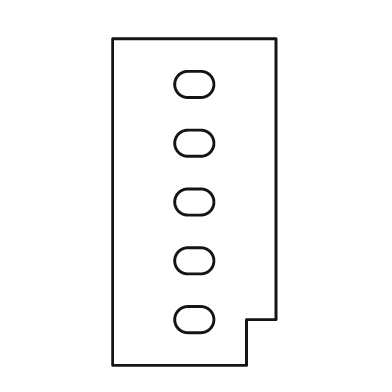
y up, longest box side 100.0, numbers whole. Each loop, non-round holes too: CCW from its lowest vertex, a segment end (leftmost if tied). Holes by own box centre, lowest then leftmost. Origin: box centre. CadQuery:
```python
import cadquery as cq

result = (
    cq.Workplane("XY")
    .moveTo(-25.0, -50.0)
    .lineTo(16.0, -50.0)
    .lineTo(16.0, -36.0)
    .lineTo(25.0, -36.0)
    .lineTo(25.0, 50.0)
    .lineTo(-25.0, 50.0)
    .close()
    .moveTo(-2.0, -40.0)
    .lineTo(2.0, -40.0)
    .threePointArc((6.0, -36.0), (2.0, -32.0))
    .lineTo(-2.0, -32.0)
    .threePointArc((-6.0, -36.0), (-2.0, -40.0))
    .close()
    .moveTo(-2.0, -22.0)
    .lineTo(2.0, -22.0)
    .threePointArc((6.0, -18.0), (2.0, -14.0))
    .lineTo(-2.0, -14.0)
    .threePointArc((-6.0, -18.0), (-2.0, -22.0))
    .close()
    .moveTo(-2.0, -4.0)
    .lineTo(2.0, -4.0)
    .threePointArc((6.0, 0.0), (2.0, 4.0))
    .lineTo(-2.0, 4.0)
    .threePointArc((-6.0, 0.0), (-2.0, -4.0))
    .close()
    .moveTo(-2.0, 14.0)
    .lineTo(2.0, 14.0)
    .threePointArc((6.0, 18.0), (2.0, 22.0))
    .lineTo(-2.0, 22.0)
    .threePointArc((-6.0, 18.0), (-2.0, 14.0))
    .close()
    .moveTo(-2.0, 32.0)
    .lineTo(2.0, 32.0)
    .threePointArc((6.0, 36.0), (2.0, 40.0))
    .lineTo(-2.0, 40.0)
    .threePointArc((-6.0, 36.0), (-2.0, 32.0))
    .close()
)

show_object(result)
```